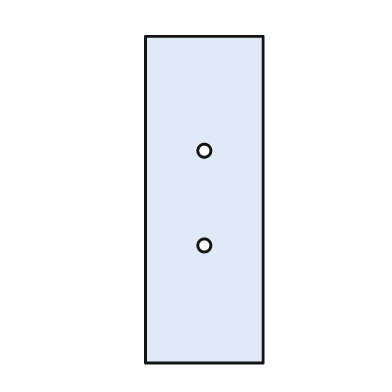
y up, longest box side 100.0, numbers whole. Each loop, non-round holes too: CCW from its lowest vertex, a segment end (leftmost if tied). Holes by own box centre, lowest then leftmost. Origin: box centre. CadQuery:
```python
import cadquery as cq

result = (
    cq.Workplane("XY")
    .moveTo(-18.0, -50.0)
    .lineTo(18.0, -50.0)
    .lineTo(18.0, 50.0)
    .lineTo(-18.0, 50.0)
    .close()
    .moveTo(0.0, -14.0)
    .circle(2.0)
    .moveTo(0.0, 15.0)
    .circle(2.0)
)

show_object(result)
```